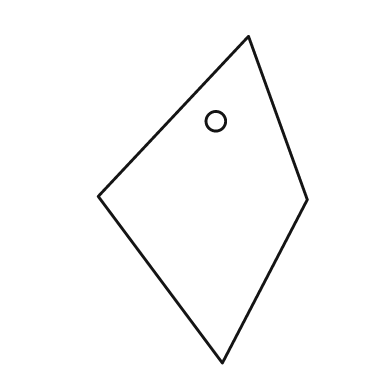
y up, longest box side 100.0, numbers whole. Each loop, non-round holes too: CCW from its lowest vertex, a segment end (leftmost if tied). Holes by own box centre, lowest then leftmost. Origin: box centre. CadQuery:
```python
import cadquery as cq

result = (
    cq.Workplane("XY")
    .moveTo(6.0, -50.0)
    .lineTo(32.0, 0.0)
    .lineTo(14.0, 50.0)
    .lineTo(-32.0, 1.0)
    .close()
    .moveTo(4.0, 24.0)
    .circle(3.0)
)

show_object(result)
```